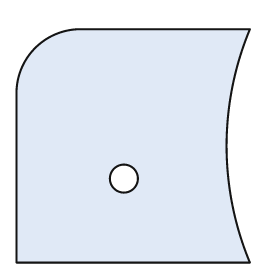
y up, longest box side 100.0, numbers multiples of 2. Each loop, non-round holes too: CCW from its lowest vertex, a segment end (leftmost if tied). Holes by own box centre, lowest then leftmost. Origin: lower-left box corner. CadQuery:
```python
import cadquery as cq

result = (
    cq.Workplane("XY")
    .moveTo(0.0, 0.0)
    .lineTo(100.0, 0.0)
    .threePointArc((90.0, 50.0), (100.0, 100.0))
    .lineTo(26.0, 100.0)
    .threePointArc((8.0, 92.0), (0.0, 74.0))
    .close()
    .moveTo(46.0, 36.0)
    .circle(6.0)
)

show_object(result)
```